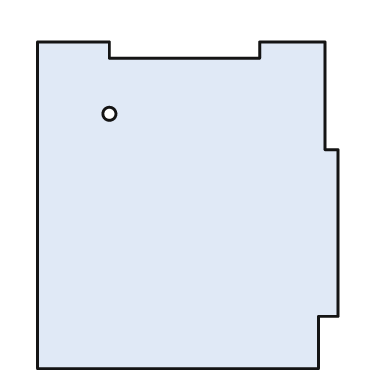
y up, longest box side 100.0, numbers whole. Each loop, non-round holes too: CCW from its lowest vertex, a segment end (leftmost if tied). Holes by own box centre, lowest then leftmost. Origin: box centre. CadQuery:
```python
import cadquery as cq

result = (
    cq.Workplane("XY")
    .moveTo(-46.0, -50.0)
    .lineTo(40.0, -50.0)
    .lineTo(40.0, -34.0)
    .lineTo(46.0, -34.0)
    .lineTo(46.0, 17.0)
    .lineTo(42.0, 17.0)
    .lineTo(42.0, 50.0)
    .lineTo(22.0, 50.0)
    .lineTo(22.0, 45.0)
    .lineTo(-24.0, 45.0)
    .lineTo(-24.0, 50.0)
    .lineTo(-46.0, 50.0)
    .close()
    .moveTo(-24.0, 28.0)
    .circle(2.0)
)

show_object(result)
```